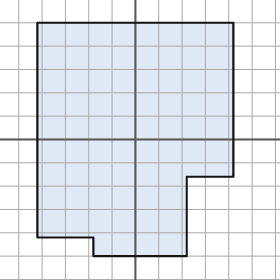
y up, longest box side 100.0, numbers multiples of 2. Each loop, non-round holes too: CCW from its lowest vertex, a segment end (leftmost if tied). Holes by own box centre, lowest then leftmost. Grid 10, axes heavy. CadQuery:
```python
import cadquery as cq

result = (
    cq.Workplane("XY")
    .moveTo(-18.0, -50.0)
    .lineTo(22.0, -50.0)
    .lineTo(22.0, -16.0)
    .lineTo(42.0, -16.0)
    .lineTo(42.0, 50.0)
    .lineTo(-42.0, 50.0)
    .lineTo(-42.0, -42.0)
    .lineTo(-18.0, -42.0)
    .close()
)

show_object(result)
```